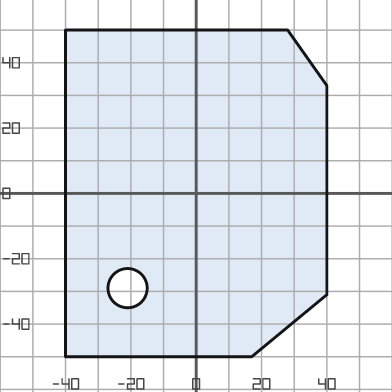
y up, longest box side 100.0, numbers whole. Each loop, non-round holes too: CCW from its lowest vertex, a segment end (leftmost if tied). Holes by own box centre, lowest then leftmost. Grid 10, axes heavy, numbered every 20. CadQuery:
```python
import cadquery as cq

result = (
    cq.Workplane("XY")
    .moveTo(-40.0, -50.0)
    .lineTo(17.0, -50.0)
    .lineTo(40.0, -31.0)
    .lineTo(40.0, 33.0)
    .lineTo(28.0, 50.0)
    .lineTo(-40.0, 50.0)
    .close()
    .moveTo(-21.0, -29.0)
    .circle(6.0)
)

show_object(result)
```